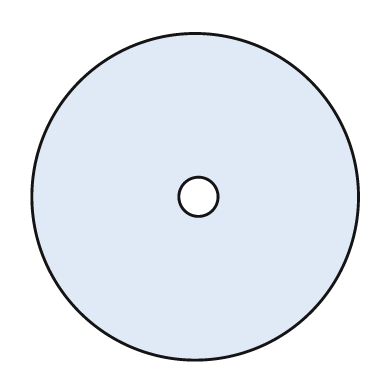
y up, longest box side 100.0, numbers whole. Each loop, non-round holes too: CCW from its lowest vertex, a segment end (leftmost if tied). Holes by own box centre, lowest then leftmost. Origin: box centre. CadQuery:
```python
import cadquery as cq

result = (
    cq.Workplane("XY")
    .moveTo(0.0, 0.0)
    .circle(50.0)
    .moveTo(1.0, 0.0)
    .circle(6.0)
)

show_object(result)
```